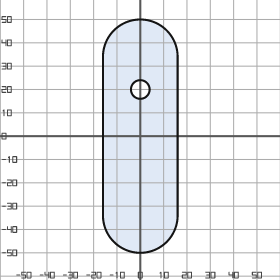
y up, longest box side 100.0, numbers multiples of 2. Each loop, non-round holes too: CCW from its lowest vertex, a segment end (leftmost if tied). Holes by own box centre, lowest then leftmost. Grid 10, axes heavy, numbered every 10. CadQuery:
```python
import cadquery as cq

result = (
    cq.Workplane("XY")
    .moveTo(-16.0, -34.0)
    .threePointArc((0.0, -50.0), (16.0, -34.0))
    .lineTo(16.0, 34.0)
    .threePointArc((0.0, 50.0), (-16.0, 34.0))
    .close()
    .moveTo(0.0, 20.0)
    .circle(4.0)
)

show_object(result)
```